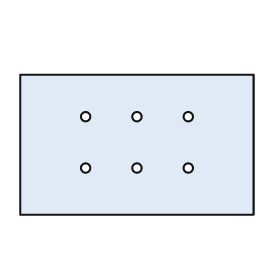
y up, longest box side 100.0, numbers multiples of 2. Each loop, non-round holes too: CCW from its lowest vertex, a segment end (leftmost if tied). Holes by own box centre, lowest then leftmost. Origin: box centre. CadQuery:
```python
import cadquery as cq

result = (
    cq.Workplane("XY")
    .moveTo(-50.0, -30.0)
    .lineTo(50.0, -30.0)
    .lineTo(50.0, 30.0)
    .lineTo(-50.0, 30.0)
    .close()
    .moveTo(-22.0, -10.0)
    .circle(2.0)
    .moveTo(0.0, -10.0)
    .circle(2.0)
    .moveTo(22.0, -10.0)
    .circle(2.0)
    .moveTo(-22.0, 12.0)
    .circle(2.0)
    .moveTo(0.0, 12.0)
    .circle(2.0)
    .moveTo(22.0, 12.0)
    .circle(2.0)
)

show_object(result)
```